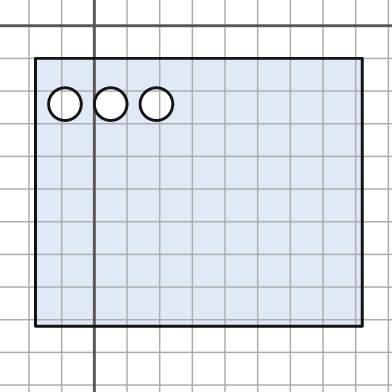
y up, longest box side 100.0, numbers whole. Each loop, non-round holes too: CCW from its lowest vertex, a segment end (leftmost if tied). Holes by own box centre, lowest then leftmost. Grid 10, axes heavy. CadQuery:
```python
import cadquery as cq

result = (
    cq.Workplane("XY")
    .moveTo(-18.0, -92.0)
    .lineTo(82.0, -92.0)
    .lineTo(82.0, -10.0)
    .lineTo(-18.0, -10.0)
    .close()
    .moveTo(-9.0, -24.0)
    .circle(5.0)
    .moveTo(5.0, -24.0)
    .circle(5.0)
    .moveTo(19.0, -24.0)
    .circle(5.0)
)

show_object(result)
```